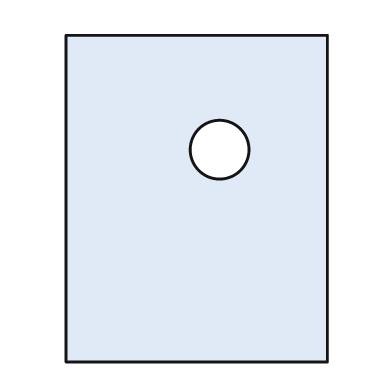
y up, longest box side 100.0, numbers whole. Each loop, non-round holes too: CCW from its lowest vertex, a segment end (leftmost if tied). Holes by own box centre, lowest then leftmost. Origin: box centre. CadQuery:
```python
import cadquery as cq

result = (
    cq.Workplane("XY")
    .moveTo(-40.0, -50.0)
    .lineTo(40.0, -50.0)
    .lineTo(40.0, 50.0)
    .lineTo(-40.0, 50.0)
    .close()
    .moveTo(7.0, 15.0)
    .circle(9.0)
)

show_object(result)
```